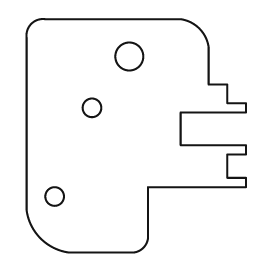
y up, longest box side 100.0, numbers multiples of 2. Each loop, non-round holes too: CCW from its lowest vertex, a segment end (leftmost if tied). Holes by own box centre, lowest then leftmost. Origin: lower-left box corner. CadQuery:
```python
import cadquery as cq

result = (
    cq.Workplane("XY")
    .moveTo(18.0, 0.0)
    .lineTo(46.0, 0.0)
    .threePointArc((50.0, 2.0), (52.0, 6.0))
    .lineTo(52.0, 28.0)
    .lineTo(94.0, 28.0)
    .lineTo(94.0, 32.0)
    .lineTo(86.0, 32.0)
    .lineTo(86.0, 42.0)
    .lineTo(94.0, 42.0)
    .lineTo(94.0, 46.0)
    .lineTo(66.0, 46.0)
    .lineTo(66.0, 60.0)
    .lineTo(94.0, 60.0)
    .lineTo(94.0, 64.0)
    .lineTo(86.0, 64.0)
    .lineTo(86.0, 72.0)
    .lineTo(78.0, 72.0)
    .lineTo(78.0, 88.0)
    .threePointArc((74.0, 96.0), (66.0, 100.0))
    .lineTo(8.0, 100.0)
    .threePointArc((2.0, 98.0), (0.0, 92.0))
    .lineTo(0.0, 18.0)
    .threePointArc((6.0, 6.0), (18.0, 0.0))
    .close()
    .moveTo(12.0, 24.0)
    .circle(4.0)
    .moveTo(28.0, 62.0)
    .circle(4.0)
    .moveTo(44.0, 84.0)
    .circle(6.0)
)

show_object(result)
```